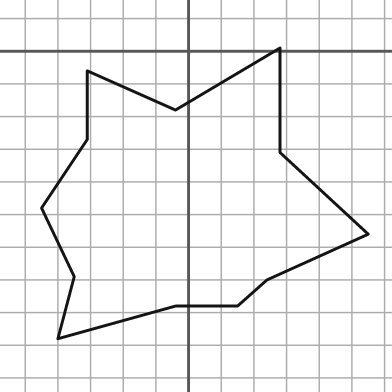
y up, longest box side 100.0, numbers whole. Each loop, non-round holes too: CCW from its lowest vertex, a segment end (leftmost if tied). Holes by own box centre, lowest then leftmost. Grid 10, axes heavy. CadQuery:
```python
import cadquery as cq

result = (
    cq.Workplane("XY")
    .moveTo(-40.0, -88.0)
    .lineTo(-4.0, -78.0)
    .lineTo(15.0, -78.0)
    .lineTo(24.0, -70.0)
    .lineTo(55.0, -56.0)
    .lineTo(28.0, -31.0)
    .lineTo(28.0, 1.0)
    .lineTo(-4.0, -18.0)
    .lineTo(-31.0, -6.0)
    .lineTo(-31.0, -27.0)
    .lineTo(-45.0, -48.0)
    .lineTo(-35.0, -69.0)
    .close()
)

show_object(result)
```